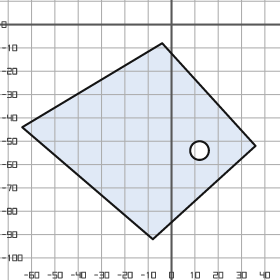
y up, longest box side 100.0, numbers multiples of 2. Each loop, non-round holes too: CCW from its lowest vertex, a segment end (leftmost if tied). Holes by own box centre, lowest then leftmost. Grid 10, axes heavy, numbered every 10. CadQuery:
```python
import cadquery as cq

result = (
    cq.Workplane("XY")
    .moveTo(-8.0, -92.0)
    .lineTo(36.0, -52.0)
    .lineTo(-4.0, -8.0)
    .lineTo(-64.0, -44.0)
    .close()
    .moveTo(12.0, -54.0)
    .circle(4.0)
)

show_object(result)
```